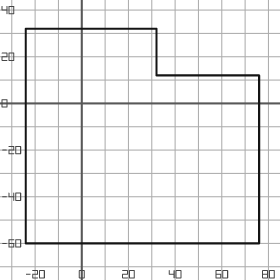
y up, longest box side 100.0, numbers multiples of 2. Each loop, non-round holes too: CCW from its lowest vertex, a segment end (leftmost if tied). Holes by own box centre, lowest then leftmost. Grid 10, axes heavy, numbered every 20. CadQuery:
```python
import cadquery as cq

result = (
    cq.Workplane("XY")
    .moveTo(-24.0, -60.0)
    .lineTo(76.0, -60.0)
    .lineTo(76.0, 12.0)
    .lineTo(32.0, 12.0)
    .lineTo(32.0, 32.0)
    .lineTo(-24.0, 32.0)
    .close()
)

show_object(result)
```